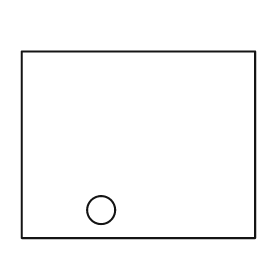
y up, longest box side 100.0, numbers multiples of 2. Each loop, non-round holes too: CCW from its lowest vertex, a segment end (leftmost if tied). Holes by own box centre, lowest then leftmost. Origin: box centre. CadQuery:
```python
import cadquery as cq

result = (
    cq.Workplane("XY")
    .moveTo(-50.0, -40.0)
    .lineTo(50.0, -40.0)
    .lineTo(50.0, 40.0)
    .lineTo(-50.0, 40.0)
    .close()
    .moveTo(-16.0, -28.0)
    .circle(6.0)
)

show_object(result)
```